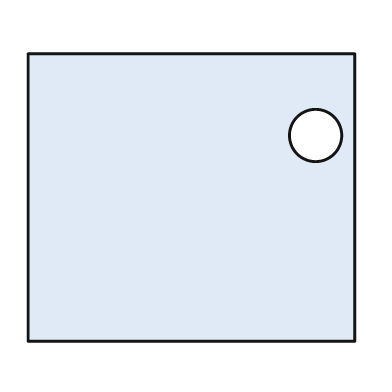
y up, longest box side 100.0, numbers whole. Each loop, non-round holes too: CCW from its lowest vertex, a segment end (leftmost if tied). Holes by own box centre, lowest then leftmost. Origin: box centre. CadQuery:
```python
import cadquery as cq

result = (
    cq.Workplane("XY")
    .moveTo(-50.0, -44.0)
    .lineTo(50.0, -44.0)
    .lineTo(50.0, 44.0)
    .lineTo(-50.0, 44.0)
    .close()
    .moveTo(38.0, 19.0)
    .circle(8.0)
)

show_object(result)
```